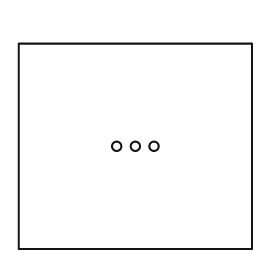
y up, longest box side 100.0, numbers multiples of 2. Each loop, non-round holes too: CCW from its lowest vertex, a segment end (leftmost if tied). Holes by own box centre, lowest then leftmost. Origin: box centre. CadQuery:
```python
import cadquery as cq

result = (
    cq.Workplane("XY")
    .moveTo(-50.0, -44.0)
    .lineTo(50.0, -44.0)
    .lineTo(50.0, 44.0)
    .lineTo(-50.0, 44.0)
    .close()
    .moveTo(-8.0, 0.0)
    .circle(2.0)
    .moveTo(0.0, 0.0)
    .circle(2.0)
    .moveTo(8.0, 0.0)
    .circle(2.0)
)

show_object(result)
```